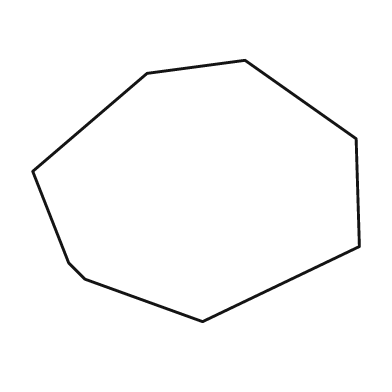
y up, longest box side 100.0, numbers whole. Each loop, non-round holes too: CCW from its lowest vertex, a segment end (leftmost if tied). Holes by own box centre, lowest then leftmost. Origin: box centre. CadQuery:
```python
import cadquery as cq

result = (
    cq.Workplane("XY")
    .moveTo(2.0, -40.0)
    .lineTo(50.0, -17.0)
    .lineTo(49.0, 16.0)
    .lineTo(15.0, 40.0)
    .lineTo(-15.0, 36.0)
    .lineTo(-50.0, 6.0)
    .lineTo(-39.0, -22.0)
    .lineTo(-34.0, -27.0)
    .close()
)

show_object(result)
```